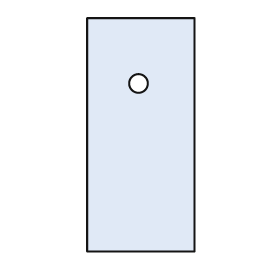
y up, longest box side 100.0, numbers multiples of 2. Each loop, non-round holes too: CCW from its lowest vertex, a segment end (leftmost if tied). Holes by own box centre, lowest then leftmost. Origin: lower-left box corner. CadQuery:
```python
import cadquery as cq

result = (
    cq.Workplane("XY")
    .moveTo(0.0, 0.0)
    .lineTo(46.0, 0.0)
    .lineTo(46.0, 100.0)
    .lineTo(0.0, 100.0)
    .close()
    .moveTo(22.0, 72.0)
    .circle(4.0)
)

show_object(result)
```